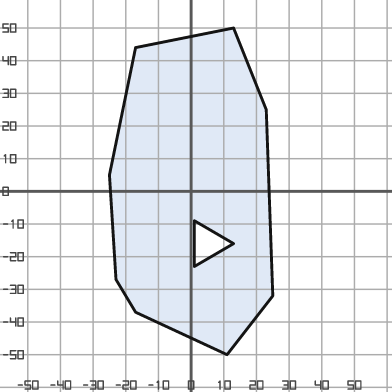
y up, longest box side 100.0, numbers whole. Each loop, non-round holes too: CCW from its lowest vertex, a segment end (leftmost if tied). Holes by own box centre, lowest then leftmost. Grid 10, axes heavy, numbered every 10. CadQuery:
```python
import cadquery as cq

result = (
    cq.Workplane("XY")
    .moveTo(11.0, -50.0)
    .lineTo(25.0, -32.0)
    .lineTo(23.0, 25.0)
    .lineTo(13.0, 50.0)
    .lineTo(-17.0, 44.0)
    .lineTo(-25.0, 5.0)
    .lineTo(-23.0, -27.0)
    .lineTo(-17.0, -37.0)
    .close()
    .moveTo(1.0, -23.0)
    .lineTo(13.0, -16.0)
    .lineTo(1.0, -9.0)
    .close()
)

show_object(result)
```